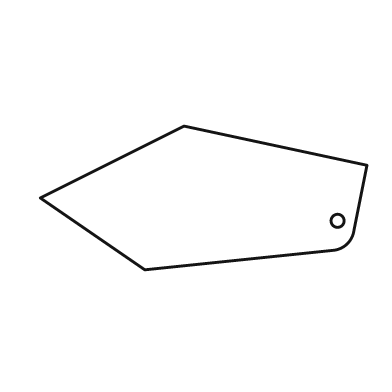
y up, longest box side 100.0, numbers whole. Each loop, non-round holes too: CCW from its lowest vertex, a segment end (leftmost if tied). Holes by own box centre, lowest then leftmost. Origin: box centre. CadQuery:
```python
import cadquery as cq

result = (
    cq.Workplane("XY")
    .moveTo(-18.0, -22.0)
    .lineTo(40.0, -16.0)
    .threePointArc((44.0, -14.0), (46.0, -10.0))
    .lineTo(50.0, 10.0)
    .lineTo(-6.0, 22.0)
    .lineTo(-50.0, 0.0)
    .close()
    .moveTo(41.0, -7.0)
    .circle(2.0)
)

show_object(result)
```